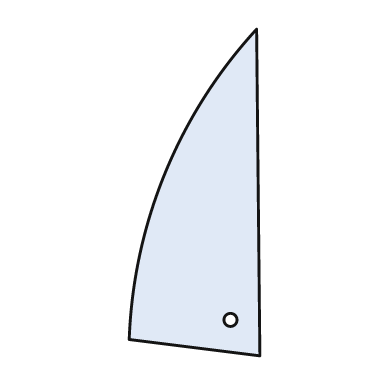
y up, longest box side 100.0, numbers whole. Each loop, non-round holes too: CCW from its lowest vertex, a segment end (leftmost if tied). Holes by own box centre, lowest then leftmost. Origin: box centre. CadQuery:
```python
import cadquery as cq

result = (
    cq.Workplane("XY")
    .moveTo(20.0, -50.0)
    .lineTo(19.0, 50.0)
    .threePointArc((-9.0, 6.0), (-20.0, -45.0))
    .close()
    .moveTo(11.0, -39.0)
    .circle(2.0)
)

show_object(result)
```